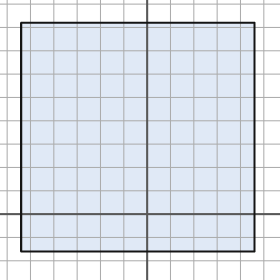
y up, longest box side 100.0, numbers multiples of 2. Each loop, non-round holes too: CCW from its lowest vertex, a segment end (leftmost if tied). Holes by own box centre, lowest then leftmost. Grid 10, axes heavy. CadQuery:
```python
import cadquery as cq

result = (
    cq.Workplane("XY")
    .moveTo(-54.0, -16.0)
    .lineTo(46.0, -16.0)
    .lineTo(46.0, 82.0)
    .lineTo(-54.0, 82.0)
    .close()
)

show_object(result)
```